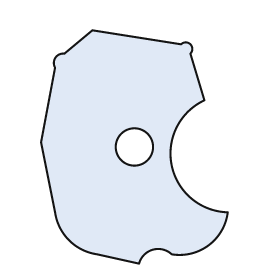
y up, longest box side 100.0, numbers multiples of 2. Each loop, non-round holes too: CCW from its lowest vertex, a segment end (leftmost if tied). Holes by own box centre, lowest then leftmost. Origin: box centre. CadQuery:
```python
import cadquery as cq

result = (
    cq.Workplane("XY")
    .moveTo(2.0, -50.0)
    .threePointArc((8.0, -44.0), (16.0, -46.0))
    .threePointArc((32.0, -42.0), (40.0, -28.0))
    .threePointArc((16.0, -8.0), (30.0, 20.0))
    .lineTo(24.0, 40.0)
    .threePointArc((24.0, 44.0), (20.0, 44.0))
    .lineTo(-18.0, 50.0)
    .lineTo(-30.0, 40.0)
    .threePointArc((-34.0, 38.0), (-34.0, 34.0))
    .lineTo(-40.0, 2.0)
    .lineTo(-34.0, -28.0)
    .threePointArc((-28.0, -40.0), (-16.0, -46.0))
    .close()
    .moveTo(0.0, 0.0)
    .circle(8.0)
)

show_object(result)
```